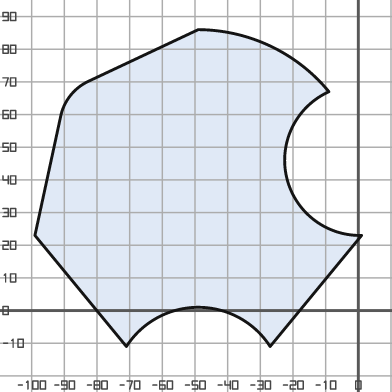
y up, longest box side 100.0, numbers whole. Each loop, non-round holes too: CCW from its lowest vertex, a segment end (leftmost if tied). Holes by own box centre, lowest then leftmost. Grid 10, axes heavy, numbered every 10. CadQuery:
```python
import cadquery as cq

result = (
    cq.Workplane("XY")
    .moveTo(-71.0, -11.0)
    .threePointArc((-49.0, 1.0), (-27.0, -11.0))
    .lineTo(1.0, 23.0)
    .threePointArc((-22.0, 41.0), (-9.0, 67.0))
    .threePointArc((-27.0, 81.0), (-49.0, 86.0))
    .lineTo(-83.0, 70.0)
    .threePointArc((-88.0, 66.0), (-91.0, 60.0))
    .lineTo(-99.0, 23.0)
    .close()
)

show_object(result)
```